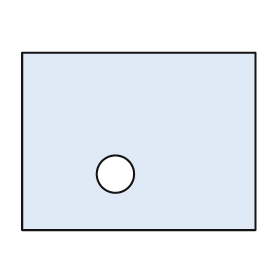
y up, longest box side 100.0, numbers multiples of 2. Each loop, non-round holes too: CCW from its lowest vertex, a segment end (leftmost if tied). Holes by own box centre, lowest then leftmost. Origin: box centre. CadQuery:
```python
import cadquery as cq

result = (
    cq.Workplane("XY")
    .moveTo(-50.0, -38.0)
    .lineTo(50.0, -38.0)
    .lineTo(50.0, 38.0)
    .lineTo(-50.0, 38.0)
    .close()
    .moveTo(-10.0, -14.0)
    .circle(8.0)
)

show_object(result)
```